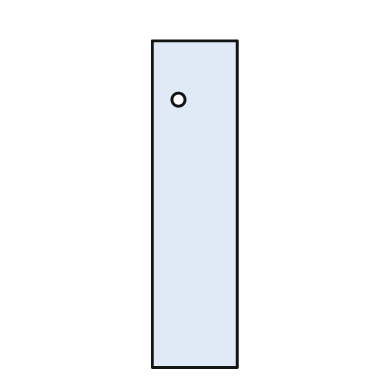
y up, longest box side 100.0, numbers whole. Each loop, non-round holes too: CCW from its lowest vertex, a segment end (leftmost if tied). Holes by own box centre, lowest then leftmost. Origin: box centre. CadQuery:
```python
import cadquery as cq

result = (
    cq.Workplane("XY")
    .moveTo(-13.0, -50.0)
    .lineTo(13.0, -50.0)
    .lineTo(13.0, 50.0)
    .lineTo(-13.0, 50.0)
    .close()
    .moveTo(-5.0, 32.0)
    .circle(2.0)
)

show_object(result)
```